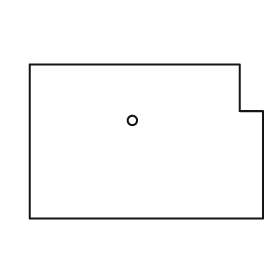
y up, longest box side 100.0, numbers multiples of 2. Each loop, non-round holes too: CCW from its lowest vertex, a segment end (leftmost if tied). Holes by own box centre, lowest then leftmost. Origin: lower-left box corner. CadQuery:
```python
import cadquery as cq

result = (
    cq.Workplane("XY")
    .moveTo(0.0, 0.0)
    .lineTo(100.0, 0.0)
    .lineTo(100.0, 46.0)
    .lineTo(90.0, 46.0)
    .lineTo(90.0, 66.0)
    .lineTo(0.0, 66.0)
    .close()
    .moveTo(44.0, 42.0)
    .circle(2.0)
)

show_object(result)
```